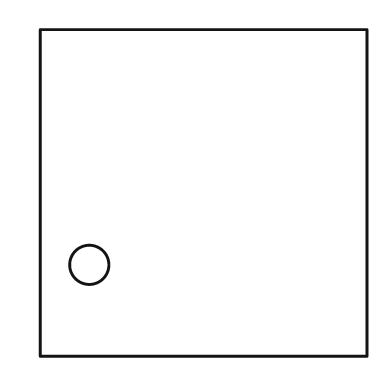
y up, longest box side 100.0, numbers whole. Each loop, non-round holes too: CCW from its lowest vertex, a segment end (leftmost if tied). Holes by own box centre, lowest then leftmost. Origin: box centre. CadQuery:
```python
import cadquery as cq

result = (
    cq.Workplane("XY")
    .moveTo(-50.0, -50.0)
    .lineTo(50.0, -50.0)
    .lineTo(50.0, 50.0)
    .lineTo(-50.0, 50.0)
    .close()
    .moveTo(-35.0, -22.0)
    .circle(6.0)
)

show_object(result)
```